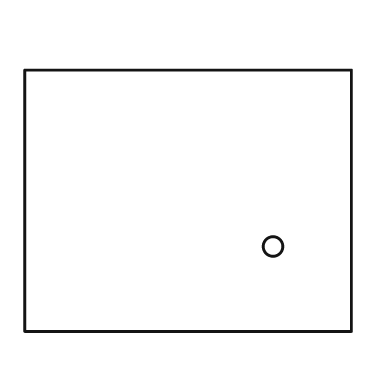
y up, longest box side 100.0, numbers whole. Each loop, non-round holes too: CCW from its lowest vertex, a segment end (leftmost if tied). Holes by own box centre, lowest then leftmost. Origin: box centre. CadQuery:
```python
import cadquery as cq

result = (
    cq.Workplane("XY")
    .moveTo(-50.0, -40.0)
    .lineTo(50.0, -40.0)
    .lineTo(50.0, 40.0)
    .lineTo(-50.0, 40.0)
    .close()
    .moveTo(26.0, -14.0)
    .circle(3.0)
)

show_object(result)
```